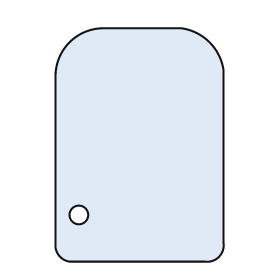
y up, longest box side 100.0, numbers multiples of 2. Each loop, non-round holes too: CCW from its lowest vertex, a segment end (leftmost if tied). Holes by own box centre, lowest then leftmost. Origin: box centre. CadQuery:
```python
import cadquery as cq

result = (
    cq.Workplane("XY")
    .moveTo(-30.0, -50.0)
    .lineTo(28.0, -50.0)
    .threePointArc((34.0, -48.0), (36.0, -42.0))
    .lineTo(36.0, 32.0)
    .threePointArc((30.0, 44.0), (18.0, 50.0))
    .lineTo(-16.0, 50.0)
    .threePointArc((-30.0, 44.0), (-36.0, 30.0))
    .lineTo(-36.0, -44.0)
    .threePointArc((-34.0, -48.0), (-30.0, -50.0))
    .close()
    .moveTo(-26.0, -30.0)
    .circle(4.0)
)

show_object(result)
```